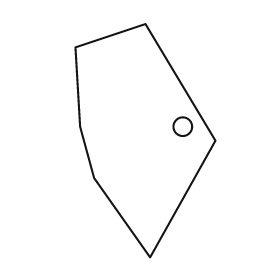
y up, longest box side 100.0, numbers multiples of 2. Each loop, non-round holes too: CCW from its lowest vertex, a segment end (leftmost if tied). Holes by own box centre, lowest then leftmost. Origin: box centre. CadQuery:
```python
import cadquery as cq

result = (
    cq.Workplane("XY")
    .moveTo(2.0, -50.0)
    .lineTo(30.0, 0.0)
    .lineTo(0.0, 50.0)
    .lineTo(-30.0, 40.0)
    .lineTo(-28.0, 6.0)
    .lineTo(-22.0, -16.0)
    .close()
    .moveTo(16.0, 6.0)
    .circle(4.0)
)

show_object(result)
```